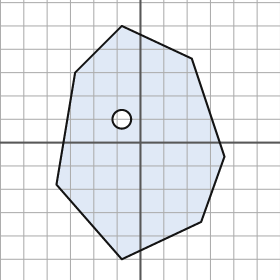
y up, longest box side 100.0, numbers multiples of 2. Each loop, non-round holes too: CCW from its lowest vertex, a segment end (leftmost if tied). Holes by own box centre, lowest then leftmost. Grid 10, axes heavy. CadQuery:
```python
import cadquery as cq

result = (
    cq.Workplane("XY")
    .moveTo(-8.0, -50.0)
    .lineTo(26.0, -34.0)
    .lineTo(36.0, -6.0)
    .lineTo(22.0, 36.0)
    .lineTo(-8.0, 50.0)
    .lineTo(-28.0, 30.0)
    .lineTo(-36.0, -18.0)
    .close()
    .moveTo(-8.0, 10.0)
    .circle(4.0)
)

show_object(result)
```